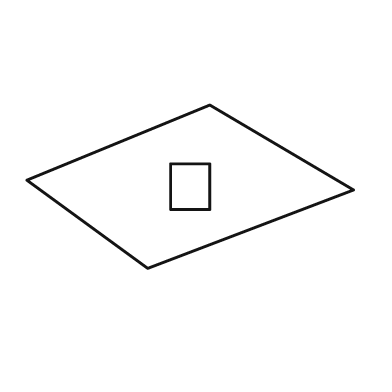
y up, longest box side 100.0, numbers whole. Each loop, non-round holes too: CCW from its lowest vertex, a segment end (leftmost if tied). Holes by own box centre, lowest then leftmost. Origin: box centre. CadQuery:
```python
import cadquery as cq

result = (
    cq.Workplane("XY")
    .moveTo(-13.0, -25.0)
    .lineTo(50.0, -1.0)
    .lineTo(6.0, 25.0)
    .lineTo(-50.0, 2.0)
    .close()
    .moveTo(-6.0, -7.0)
    .lineTo(6.0, -7.0)
    .lineTo(6.0, 7.0)
    .lineTo(-6.0, 7.0)
    .close()
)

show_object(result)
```